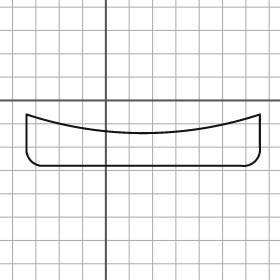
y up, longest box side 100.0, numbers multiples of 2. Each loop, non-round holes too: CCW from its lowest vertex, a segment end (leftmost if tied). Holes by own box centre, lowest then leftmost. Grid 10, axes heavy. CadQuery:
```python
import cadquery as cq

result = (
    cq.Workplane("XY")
    .moveTo(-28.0, -28.0)
    .lineTo(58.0, -28.0)
    .threePointArc((64.0, -26.0), (66.0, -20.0))
    .lineTo(66.0, -6.0)
    .threePointArc((16.0, -14.0), (-34.0, -6.0))
    .lineTo(-34.0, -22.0)
    .threePointArc((-32.0, -26.0), (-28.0, -28.0))
    .close()
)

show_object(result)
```